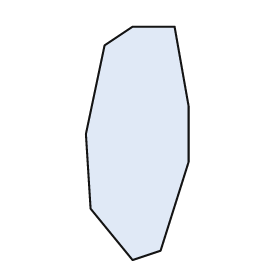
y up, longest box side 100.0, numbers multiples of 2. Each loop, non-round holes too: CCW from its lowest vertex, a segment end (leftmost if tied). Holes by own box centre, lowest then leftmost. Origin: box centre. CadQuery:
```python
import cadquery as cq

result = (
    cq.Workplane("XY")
    .moveTo(-2.0, -50.0)
    .lineTo(10.0, -46.0)
    .lineTo(22.0, -8.0)
    .lineTo(22.0, 16.0)
    .lineTo(16.0, 50.0)
    .lineTo(-2.0, 50.0)
    .lineTo(-14.0, 42.0)
    .lineTo(-22.0, 4.0)
    .lineTo(-20.0, -28.0)
    .close()
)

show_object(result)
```